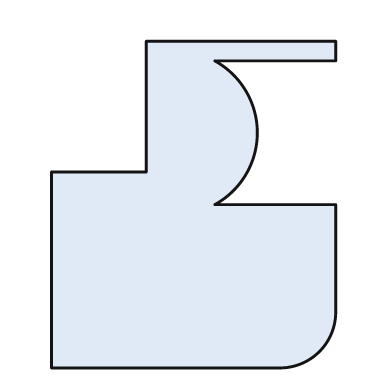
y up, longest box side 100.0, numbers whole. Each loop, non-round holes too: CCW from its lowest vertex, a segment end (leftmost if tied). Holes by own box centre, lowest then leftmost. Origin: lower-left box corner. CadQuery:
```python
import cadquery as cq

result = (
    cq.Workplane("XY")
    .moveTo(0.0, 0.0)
    .lineTo(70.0, 0.0)
    .threePointArc((82.0, 5.0), (87.0, 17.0))
    .lineTo(87.0, 50.0)
    .lineTo(50.0, 50.0)
    .threePointArc((63.0, 72.0), (50.0, 94.0))
    .lineTo(87.0, 94.0)
    .lineTo(87.0, 100.0)
    .lineTo(29.0, 100.0)
    .lineTo(29.0, 60.0)
    .lineTo(0.0, 60.0)
    .close()
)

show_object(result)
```